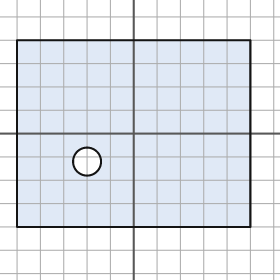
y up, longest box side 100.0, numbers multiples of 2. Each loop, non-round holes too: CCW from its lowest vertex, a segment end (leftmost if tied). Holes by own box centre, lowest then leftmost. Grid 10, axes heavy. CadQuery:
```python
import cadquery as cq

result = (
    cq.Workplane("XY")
    .moveTo(-50.0, -40.0)
    .lineTo(50.0, -40.0)
    .lineTo(50.0, 40.0)
    .lineTo(-50.0, 40.0)
    .close()
    .moveTo(-20.0, -12.0)
    .circle(6.0)
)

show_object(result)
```